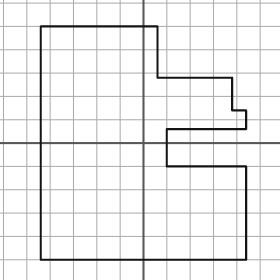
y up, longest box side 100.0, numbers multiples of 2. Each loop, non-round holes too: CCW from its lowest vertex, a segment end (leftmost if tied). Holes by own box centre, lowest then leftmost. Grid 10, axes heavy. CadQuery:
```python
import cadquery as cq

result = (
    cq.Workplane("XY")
    .moveTo(-44.0, -50.0)
    .lineTo(44.0, -50.0)
    .lineTo(44.0, -10.0)
    .lineTo(10.0, -10.0)
    .lineTo(10.0, 6.0)
    .lineTo(44.0, 6.0)
    .lineTo(44.0, 14.0)
    .lineTo(38.0, 14.0)
    .lineTo(38.0, 28.0)
    .lineTo(6.0, 28.0)
    .lineTo(6.0, 50.0)
    .lineTo(-44.0, 50.0)
    .close()
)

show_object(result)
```